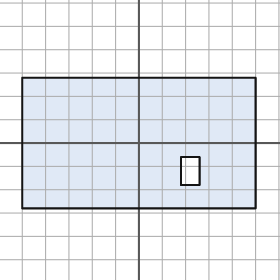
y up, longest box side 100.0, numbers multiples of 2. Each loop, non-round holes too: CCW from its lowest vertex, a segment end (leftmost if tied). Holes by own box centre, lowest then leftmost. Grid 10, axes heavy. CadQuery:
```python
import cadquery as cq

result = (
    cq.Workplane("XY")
    .moveTo(-50.0, -28.0)
    .lineTo(50.0, -28.0)
    .lineTo(50.0, 28.0)
    .lineTo(-50.0, 28.0)
    .close()
    .moveTo(18.0, -18.0)
    .lineTo(26.0, -18.0)
    .lineTo(26.0, -6.0)
    .lineTo(18.0, -6.0)
    .close()
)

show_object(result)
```